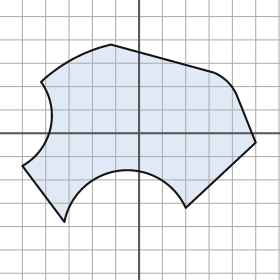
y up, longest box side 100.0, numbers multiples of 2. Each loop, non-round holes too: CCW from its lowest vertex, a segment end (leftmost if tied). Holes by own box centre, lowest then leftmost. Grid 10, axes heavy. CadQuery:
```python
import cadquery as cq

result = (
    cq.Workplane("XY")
    .moveTo(-32.0, -38.0)
    .threePointArc((-8.0, -16.0), (20.0, -32.0))
    .lineTo(50.0, -4.0)
    .lineTo(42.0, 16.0)
    .threePointArc((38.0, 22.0), (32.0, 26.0))
    .lineTo(-12.0, 38.0)
    .threePointArc((-28.0, 32.0), (-42.0, 22.0))
    .threePointArc((-38.0, 2.0), (-50.0, -14.0))
    .close()
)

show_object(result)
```